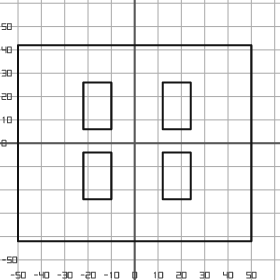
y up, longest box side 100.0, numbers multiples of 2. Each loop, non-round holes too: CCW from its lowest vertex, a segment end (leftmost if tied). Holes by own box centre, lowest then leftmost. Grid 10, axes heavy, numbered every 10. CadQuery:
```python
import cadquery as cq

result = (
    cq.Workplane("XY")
    .moveTo(-50.0, -42.0)
    .lineTo(50.0, -42.0)
    .lineTo(50.0, 42.0)
    .lineTo(-50.0, 42.0)
    .close()
    .moveTo(-22.0, -24.0)
    .lineTo(-10.0, -24.0)
    .lineTo(-10.0, -4.0)
    .lineTo(-22.0, -4.0)
    .close()
    .moveTo(12.0, -24.0)
    .lineTo(24.0, -24.0)
    .lineTo(24.0, -4.0)
    .lineTo(12.0, -4.0)
    .close()
    .moveTo(-22.0, 6.0)
    .lineTo(-10.0, 6.0)
    .lineTo(-10.0, 26.0)
    .lineTo(-22.0, 26.0)
    .close()
    .moveTo(12.0, 6.0)
    .lineTo(24.0, 6.0)
    .lineTo(24.0, 26.0)
    .lineTo(12.0, 26.0)
    .close()
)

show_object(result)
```